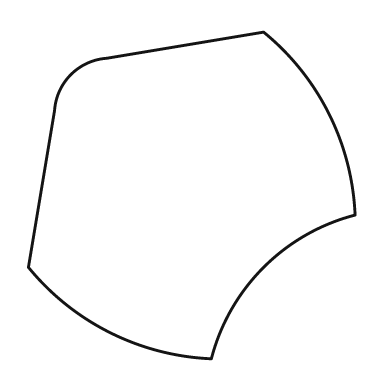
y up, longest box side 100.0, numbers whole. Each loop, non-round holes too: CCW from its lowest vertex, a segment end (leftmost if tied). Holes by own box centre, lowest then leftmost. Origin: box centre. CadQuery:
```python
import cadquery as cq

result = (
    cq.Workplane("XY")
    .moveTo(6.0, -50.0)
    .threePointArc((22.0, -22.0), (50.0, -6.0))
    .threePointArc((42.0, 25.0), (22.0, 50.0))
    .lineTo(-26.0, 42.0)
    .threePointArc((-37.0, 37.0), (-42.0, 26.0))
    .lineTo(-50.0, -22.0)
    .threePointArc((-25.0, -42.0), (6.0, -50.0))
    .close()
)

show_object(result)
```